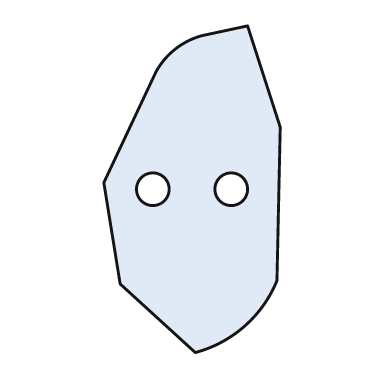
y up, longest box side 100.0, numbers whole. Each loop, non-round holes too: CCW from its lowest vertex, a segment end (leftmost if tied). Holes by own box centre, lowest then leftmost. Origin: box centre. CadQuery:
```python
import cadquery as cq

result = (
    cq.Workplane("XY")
    .moveTo(1.0, -50.0)
    .threePointArc((16.0, -42.0), (26.0, -28.0))
    .lineTo(27.0, 19.0)
    .lineTo(17.0, 50.0)
    .lineTo(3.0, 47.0)
    .threePointArc((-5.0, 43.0), (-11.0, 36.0))
    .lineTo(-27.0, 2.0)
    .lineTo(-22.0, -29.0)
    .close()
    .moveTo(-12.0, 0.0)
    .circle(5.0)
    .moveTo(12.0, 0.0)
    .circle(5.0)
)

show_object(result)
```